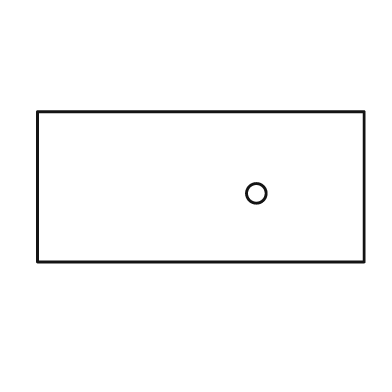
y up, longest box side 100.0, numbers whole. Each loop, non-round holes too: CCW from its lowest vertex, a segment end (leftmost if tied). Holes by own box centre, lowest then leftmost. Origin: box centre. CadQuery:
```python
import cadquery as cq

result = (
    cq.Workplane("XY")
    .moveTo(-50.0, -23.0)
    .lineTo(50.0, -23.0)
    .lineTo(50.0, 23.0)
    .lineTo(-50.0, 23.0)
    .close()
    .moveTo(17.0, -2.0)
    .circle(3.0)
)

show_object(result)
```